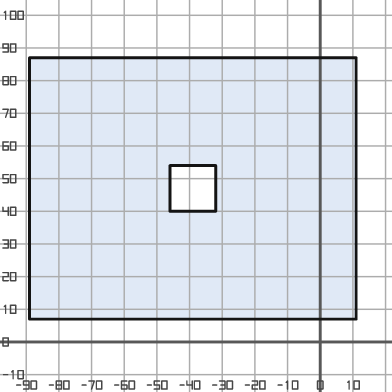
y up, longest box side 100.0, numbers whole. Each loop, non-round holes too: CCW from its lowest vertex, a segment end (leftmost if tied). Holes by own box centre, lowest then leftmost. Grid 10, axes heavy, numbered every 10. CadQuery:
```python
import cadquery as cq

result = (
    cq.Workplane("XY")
    .moveTo(-89.0, 7.0)
    .lineTo(11.0, 7.0)
    .lineTo(11.0, 87.0)
    .lineTo(-89.0, 87.0)
    .close()
    .moveTo(-46.0, 40.0)
    .lineTo(-32.0, 40.0)
    .lineTo(-32.0, 54.0)
    .lineTo(-46.0, 54.0)
    .close()
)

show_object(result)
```